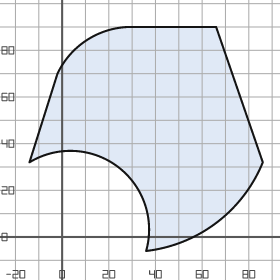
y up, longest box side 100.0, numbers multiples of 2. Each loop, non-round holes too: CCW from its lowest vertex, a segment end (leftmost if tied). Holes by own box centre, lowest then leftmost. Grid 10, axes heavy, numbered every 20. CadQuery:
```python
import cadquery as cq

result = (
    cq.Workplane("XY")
    .moveTo(36.0, -6.0)
    .threePointArc((66.0, 6.0), (86.0, 32.0))
    .lineTo(66.0, 90.0)
    .lineTo(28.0, 90.0)
    .threePointArc((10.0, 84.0), (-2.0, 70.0))
    .lineTo(-14.0, 32.0)
    .threePointArc((24.0, 30.0), (36.0, -6.0))
    .close()
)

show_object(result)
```